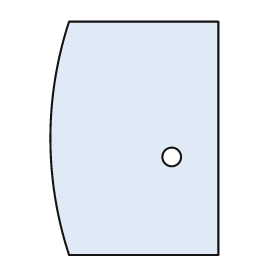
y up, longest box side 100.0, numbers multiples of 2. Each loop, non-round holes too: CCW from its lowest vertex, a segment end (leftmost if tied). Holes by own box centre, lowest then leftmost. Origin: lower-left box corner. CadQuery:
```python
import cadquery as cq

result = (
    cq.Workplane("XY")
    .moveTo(8.0, 0.0)
    .lineTo(72.0, 0.0)
    .lineTo(72.0, 100.0)
    .lineTo(8.0, 100.0)
    .threePointArc((0.0, 50.0), (8.0, 0.0))
    .close()
    .moveTo(52.0, 42.0)
    .circle(4.0)
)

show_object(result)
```